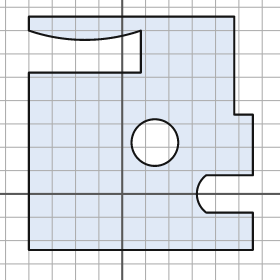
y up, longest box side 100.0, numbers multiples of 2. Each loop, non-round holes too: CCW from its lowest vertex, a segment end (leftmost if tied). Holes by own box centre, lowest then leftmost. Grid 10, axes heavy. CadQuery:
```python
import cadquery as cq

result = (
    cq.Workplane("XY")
    .moveTo(-40.0, -24.0)
    .lineTo(56.0, -24.0)
    .lineTo(56.0, -8.0)
    .lineTo(36.0, -8.0)
    .threePointArc((32.0, 0.0), (36.0, 8.0))
    .lineTo(56.0, 8.0)
    .lineTo(56.0, 34.0)
    .lineTo(48.0, 34.0)
    .lineTo(48.0, 76.0)
    .lineTo(-40.0, 76.0)
    .lineTo(-40.0, 70.0)
    .threePointArc((-16.0, 66.0), (8.0, 70.0))
    .lineTo(8.0, 52.0)
    .lineTo(-40.0, 52.0)
    .close()
    .moveTo(14.0, 22.0)
    .circle(10.0)
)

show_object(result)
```